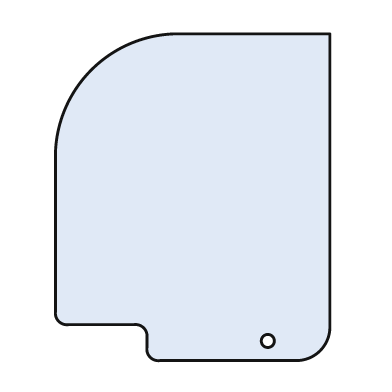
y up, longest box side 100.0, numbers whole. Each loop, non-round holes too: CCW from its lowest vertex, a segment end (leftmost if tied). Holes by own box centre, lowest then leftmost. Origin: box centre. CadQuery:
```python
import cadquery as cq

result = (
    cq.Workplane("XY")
    .moveTo(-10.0, -50.0)
    .lineTo(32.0, -50.0)
    .threePointArc((39.0, -47.0), (42.0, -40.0))
    .lineTo(42.0, 50.0)
    .lineTo(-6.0, 50.0)
    .threePointArc((-31.0, 39.0), (-42.0, 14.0))
    .lineTo(-42.0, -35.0)
    .threePointArc((-41.0, -38.0), (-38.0, -39.0))
    .lineTo(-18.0, -39.0)
    .threePointArc((-15.0, -40.0), (-14.0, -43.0))
    .lineTo(-14.0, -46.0)
    .threePointArc((-13.0, -49.0), (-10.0, -50.0))
    .close()
    .moveTo(23.0, -44.0)
    .circle(2.0)
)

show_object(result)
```